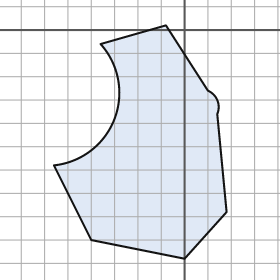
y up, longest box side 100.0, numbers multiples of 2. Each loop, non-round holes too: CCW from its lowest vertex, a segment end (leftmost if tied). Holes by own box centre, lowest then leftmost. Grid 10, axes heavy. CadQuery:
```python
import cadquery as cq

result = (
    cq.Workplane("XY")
    .moveTo(0.0, -98.0)
    .lineTo(18.0, -78.0)
    .lineTo(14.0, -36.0)
    .threePointArc((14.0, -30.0), (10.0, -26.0))
    .lineTo(-8.0, 2.0)
    .lineTo(-36.0, -6.0)
    .threePointArc((-30.0, -38.0), (-56.0, -58.0))
    .lineTo(-40.0, -90.0)
    .close()
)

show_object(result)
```